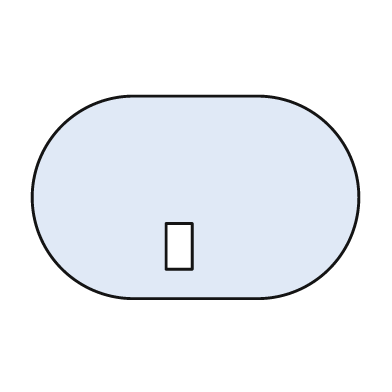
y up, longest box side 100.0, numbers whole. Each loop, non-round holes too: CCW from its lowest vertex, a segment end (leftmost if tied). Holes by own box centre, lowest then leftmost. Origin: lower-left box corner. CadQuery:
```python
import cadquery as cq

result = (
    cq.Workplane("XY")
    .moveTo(31.0, 0.0)
    .lineTo(69.0, 0.0)
    .threePointArc((100.0, 31.0), (69.0, 62.0))
    .lineTo(31.0, 62.0)
    .threePointArc((0.0, 31.0), (31.0, 0.0))
    .close()
    .moveTo(41.0, 9.0)
    .lineTo(49.0, 9.0)
    .lineTo(49.0, 23.0)
    .lineTo(41.0, 23.0)
    .close()
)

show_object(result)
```